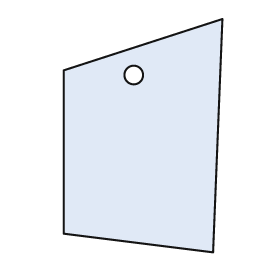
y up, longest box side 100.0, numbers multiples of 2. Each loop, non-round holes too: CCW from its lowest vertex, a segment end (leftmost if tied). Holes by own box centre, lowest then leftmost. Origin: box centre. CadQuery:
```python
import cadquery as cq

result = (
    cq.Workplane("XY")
    .moveTo(30.0, -50.0)
    .lineTo(34.0, 50.0)
    .lineTo(-34.0, 28.0)
    .lineTo(-34.0, -42.0)
    .close()
    .moveTo(-4.0, 26.0)
    .circle(4.0)
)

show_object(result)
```